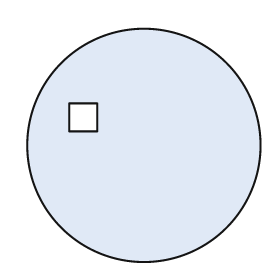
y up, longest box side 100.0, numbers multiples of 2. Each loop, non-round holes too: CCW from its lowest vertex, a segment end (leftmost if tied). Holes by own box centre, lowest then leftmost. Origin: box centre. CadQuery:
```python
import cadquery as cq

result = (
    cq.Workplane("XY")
    .moveTo(0.0, 0.0)
    .circle(50.0)
    .moveTo(-32.0, 6.0)
    .lineTo(-20.0, 6.0)
    .lineTo(-20.0, 18.0)
    .lineTo(-32.0, 18.0)
    .close()
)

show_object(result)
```